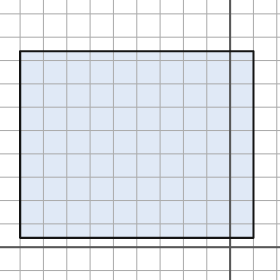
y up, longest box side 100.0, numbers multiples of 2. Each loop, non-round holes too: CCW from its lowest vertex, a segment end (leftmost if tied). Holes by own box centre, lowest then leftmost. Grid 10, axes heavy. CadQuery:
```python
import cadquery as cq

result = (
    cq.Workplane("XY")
    .moveTo(-90.0, 4.0)
    .lineTo(10.0, 4.0)
    .lineTo(10.0, 84.0)
    .lineTo(-90.0, 84.0)
    .close()
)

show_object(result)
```